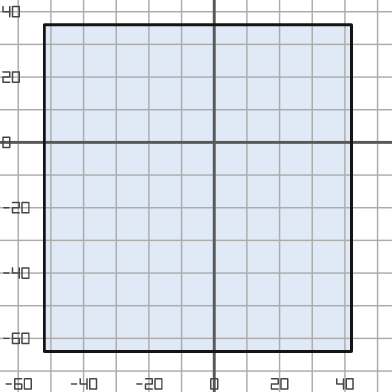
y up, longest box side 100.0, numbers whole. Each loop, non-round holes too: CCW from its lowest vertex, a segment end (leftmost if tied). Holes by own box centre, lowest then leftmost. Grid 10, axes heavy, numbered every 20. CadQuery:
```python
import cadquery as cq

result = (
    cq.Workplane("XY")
    .moveTo(-52.0, -64.0)
    .lineTo(42.0, -64.0)
    .lineTo(42.0, 36.0)
    .lineTo(-52.0, 36.0)
    .close()
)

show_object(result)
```